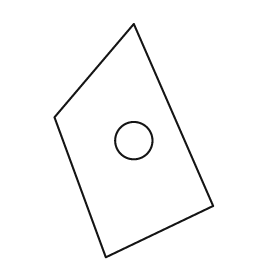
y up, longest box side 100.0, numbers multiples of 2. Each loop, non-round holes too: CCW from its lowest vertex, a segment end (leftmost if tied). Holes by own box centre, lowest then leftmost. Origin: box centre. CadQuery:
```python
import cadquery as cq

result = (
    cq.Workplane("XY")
    .moveTo(-12.0, -50.0)
    .lineTo(34.0, -28.0)
    .lineTo(0.0, 50.0)
    .lineTo(-34.0, 10.0)
    .close()
    .moveTo(0.0, 0.0)
    .circle(8.0)
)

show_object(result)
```